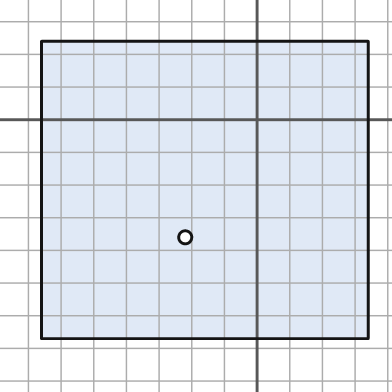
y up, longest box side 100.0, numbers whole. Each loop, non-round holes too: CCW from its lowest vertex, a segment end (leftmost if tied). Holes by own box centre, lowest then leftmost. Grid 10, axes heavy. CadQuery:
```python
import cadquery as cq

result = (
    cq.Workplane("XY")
    .moveTo(-66.0, -67.0)
    .lineTo(34.0, -67.0)
    .lineTo(34.0, 24.0)
    .lineTo(-66.0, 24.0)
    .close()
    .moveTo(-22.0, -36.0)
    .circle(2.0)
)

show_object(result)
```